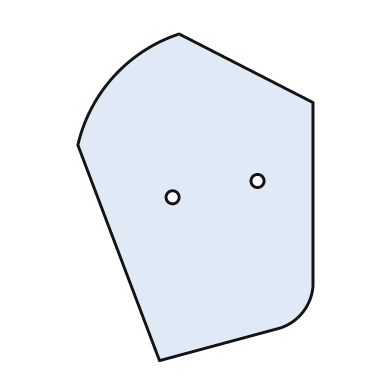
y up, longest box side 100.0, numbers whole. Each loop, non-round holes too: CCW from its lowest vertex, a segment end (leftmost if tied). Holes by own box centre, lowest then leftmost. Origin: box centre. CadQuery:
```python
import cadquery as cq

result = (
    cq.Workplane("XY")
    .moveTo(-11.0, -50.0)
    .lineTo(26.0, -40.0)
    .threePointArc((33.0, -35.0), (36.0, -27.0))
    .lineTo(36.0, 29.0)
    .lineTo(-5.0, 50.0)
    .threePointArc((-25.0, 37.0), (-36.0, 16.0))
    .close()
    .moveTo(-7.0, 0.0)
    .circle(2.0)
    .moveTo(19.0, 5.0)
    .circle(2.0)
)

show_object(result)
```